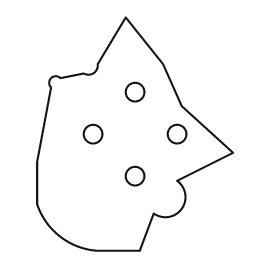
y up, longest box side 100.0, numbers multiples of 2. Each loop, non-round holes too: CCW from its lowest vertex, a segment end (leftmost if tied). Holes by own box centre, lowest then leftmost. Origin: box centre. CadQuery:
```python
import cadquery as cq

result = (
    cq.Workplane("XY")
    .moveTo(-16.0, -50.0)
    .lineTo(2.0, -50.0)
    .lineTo(8.0, -34.0)
    .threePointArc((20.0, -32.0), (18.0, -20.0))
    .lineTo(42.0, -8.0)
    .lineTo(20.0, 12.0)
    .lineTo(12.0, 30.0)
    .lineTo(-4.0, 50.0)
    .lineTo(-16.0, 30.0)
    .threePointArc((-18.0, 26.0), (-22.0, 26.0))
    .lineTo(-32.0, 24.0)
    .threePointArc((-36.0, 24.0), (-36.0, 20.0))
    .lineTo(-42.0, -12.0)
    .lineTo(-42.0, -30.0)
    .threePointArc((-32.0, -44.0), (-16.0, -50.0))
    .close()
    .moveTo(0.0, -18.0)
    .circle(4.0)
    .moveTo(-18.0, 0.0)
    .circle(4.0)
    .moveTo(18.0, 0.0)
    .circle(4.0)
    .moveTo(0.0, 18.0)
    .circle(4.0)
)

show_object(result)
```